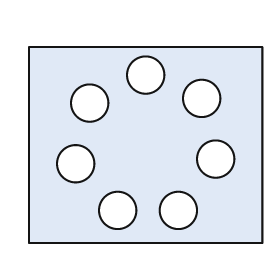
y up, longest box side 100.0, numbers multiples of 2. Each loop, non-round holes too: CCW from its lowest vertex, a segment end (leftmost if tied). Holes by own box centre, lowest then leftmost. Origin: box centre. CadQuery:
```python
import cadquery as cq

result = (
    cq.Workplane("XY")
    .moveTo(-50.0, -42.0)
    .lineTo(50.0, -42.0)
    .lineTo(50.0, 42.0)
    .lineTo(-50.0, 42.0)
    .close()
    .moveTo(-12.0, -28.0)
    .circle(8.0)
    .moveTo(14.0, -28.0)
    .circle(8.0)
    .moveTo(-30.0, -8.0)
    .circle(8.0)
    .moveTo(30.0, -6.0)
    .circle(8.0)
    .moveTo(-24.0, 18.0)
    .circle(8.0)
    .moveTo(24.0, 20.0)
    .circle(8.0)
    .moveTo(0.0, 30.0)
    .circle(8.0)
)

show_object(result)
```